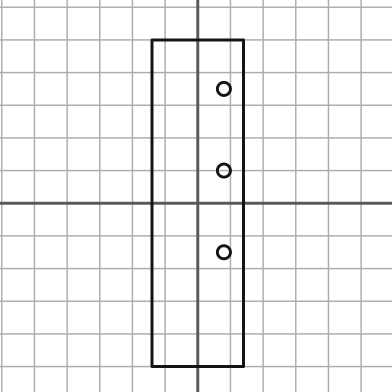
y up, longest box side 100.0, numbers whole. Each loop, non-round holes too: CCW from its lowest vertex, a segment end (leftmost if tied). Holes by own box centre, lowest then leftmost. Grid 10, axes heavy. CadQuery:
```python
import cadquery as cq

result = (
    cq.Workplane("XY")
    .moveTo(-14.0, -50.0)
    .lineTo(14.0, -50.0)
    .lineTo(14.0, 50.0)
    .lineTo(-14.0, 50.0)
    .close()
    .moveTo(8.0, -15.0)
    .circle(2.0)
    .moveTo(8.0, 10.0)
    .circle(2.0)
    .moveTo(8.0, 35.0)
    .circle(2.0)
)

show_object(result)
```